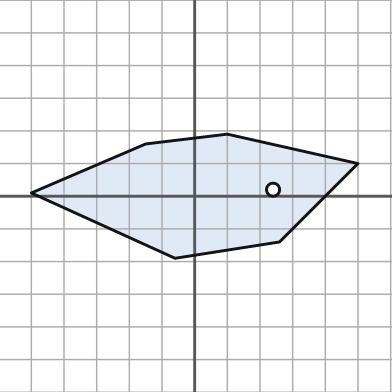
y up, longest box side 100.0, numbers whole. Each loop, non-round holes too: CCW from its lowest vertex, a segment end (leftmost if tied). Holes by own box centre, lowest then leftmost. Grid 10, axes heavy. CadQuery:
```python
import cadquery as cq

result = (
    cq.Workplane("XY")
    .moveTo(-6.0, -19.0)
    .lineTo(26.0, -14.0)
    .lineTo(50.0, 10.0)
    .lineTo(10.0, 19.0)
    .lineTo(-15.0, 16.0)
    .lineTo(-50.0, 1.0)
    .close()
    .moveTo(24.0, 2.0)
    .circle(2.0)
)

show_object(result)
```